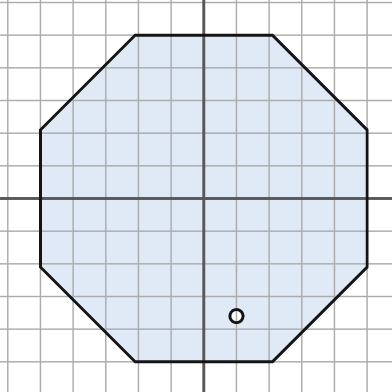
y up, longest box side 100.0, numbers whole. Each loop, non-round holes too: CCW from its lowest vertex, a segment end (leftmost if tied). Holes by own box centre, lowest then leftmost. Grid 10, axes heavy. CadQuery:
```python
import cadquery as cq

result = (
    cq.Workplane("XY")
    .moveTo(-21.0, -50.0)
    .lineTo(21.0, -50.0)
    .lineTo(50.0, -21.0)
    .lineTo(50.0, 21.0)
    .lineTo(21.0, 50.0)
    .lineTo(-21.0, 50.0)
    .lineTo(-50.0, 21.0)
    .lineTo(-50.0, -21.0)
    .close()
    .moveTo(10.0, -36.0)
    .circle(2.0)
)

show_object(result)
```